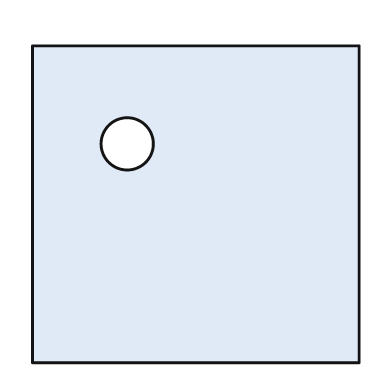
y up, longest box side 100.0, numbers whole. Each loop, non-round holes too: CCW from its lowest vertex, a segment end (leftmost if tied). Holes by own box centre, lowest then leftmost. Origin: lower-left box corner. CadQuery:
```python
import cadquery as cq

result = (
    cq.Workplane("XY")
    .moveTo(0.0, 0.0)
    .lineTo(100.0, 0.0)
    .lineTo(100.0, 97.0)
    .lineTo(0.0, 97.0)
    .close()
    .moveTo(29.0, 67.0)
    .circle(8.0)
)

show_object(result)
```